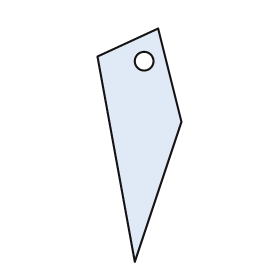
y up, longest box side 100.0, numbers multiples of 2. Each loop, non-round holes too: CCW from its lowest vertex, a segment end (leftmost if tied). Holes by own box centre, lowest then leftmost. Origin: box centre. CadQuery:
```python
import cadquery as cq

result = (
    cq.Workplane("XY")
    .moveTo(-2.0, -50.0)
    .lineTo(18.0, 10.0)
    .lineTo(8.0, 50.0)
    .lineTo(-18.0, 38.0)
    .close()
    .moveTo(2.0, 36.0)
    .circle(4.0)
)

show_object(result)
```